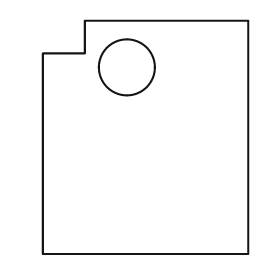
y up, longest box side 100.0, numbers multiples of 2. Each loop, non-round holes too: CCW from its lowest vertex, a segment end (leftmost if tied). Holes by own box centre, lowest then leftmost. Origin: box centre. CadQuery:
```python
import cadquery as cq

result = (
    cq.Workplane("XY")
    .moveTo(-44.0, -50.0)
    .lineTo(44.0, -50.0)
    .lineTo(44.0, 50.0)
    .lineTo(-26.0, 50.0)
    .lineTo(-26.0, 36.0)
    .lineTo(-44.0, 36.0)
    .close()
    .moveTo(-8.0, 30.0)
    .circle(12.0)
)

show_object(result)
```